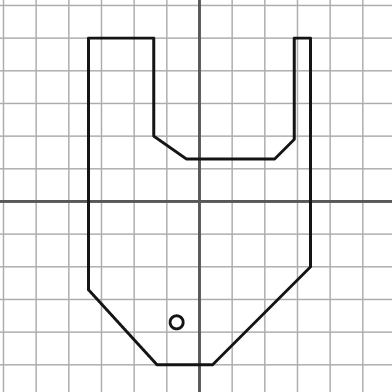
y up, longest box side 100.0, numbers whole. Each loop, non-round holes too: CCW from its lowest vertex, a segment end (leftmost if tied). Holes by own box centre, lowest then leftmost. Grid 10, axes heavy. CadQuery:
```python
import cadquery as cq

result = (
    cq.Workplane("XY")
    .moveTo(-13.0, -50.0)
    .lineTo(4.0, -50.0)
    .lineTo(34.0, -20.0)
    .lineTo(34.0, 50.0)
    .lineTo(29.0, 50.0)
    .lineTo(29.0, 19.0)
    .lineTo(23.0, 13.0)
    .lineTo(-4.0, 13.0)
    .lineTo(-14.0, 20.0)
    .lineTo(-14.0, 50.0)
    .lineTo(-34.0, 50.0)
    .lineTo(-34.0, -27.0)
    .close()
    .moveTo(-7.0, -37.0)
    .circle(2.0)
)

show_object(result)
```